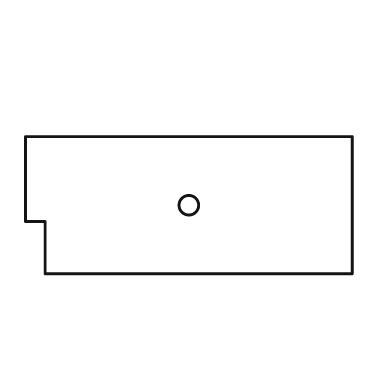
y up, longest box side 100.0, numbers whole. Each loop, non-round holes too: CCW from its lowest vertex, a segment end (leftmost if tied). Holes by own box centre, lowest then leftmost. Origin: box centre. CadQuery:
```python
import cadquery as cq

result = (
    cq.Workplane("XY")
    .moveTo(-44.0, -21.0)
    .lineTo(50.0, -21.0)
    .lineTo(50.0, 21.0)
    .lineTo(-50.0, 21.0)
    .lineTo(-50.0, -5.0)
    .lineTo(-44.0, -5.0)
    .close()
    .moveTo(0.0, 0.0)
    .circle(3.0)
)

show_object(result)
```